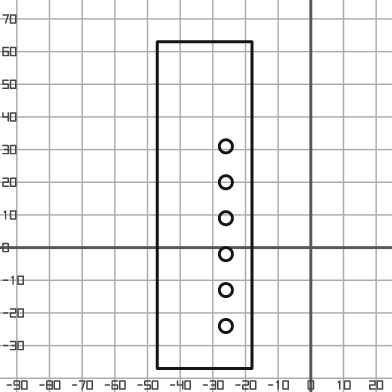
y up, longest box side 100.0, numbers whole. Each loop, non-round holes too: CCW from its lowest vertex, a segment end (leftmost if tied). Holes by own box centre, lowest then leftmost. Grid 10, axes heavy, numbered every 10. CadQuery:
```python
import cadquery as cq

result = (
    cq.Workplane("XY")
    .moveTo(-47.0, -37.0)
    .lineTo(-18.0, -37.0)
    .lineTo(-18.0, 63.0)
    .lineTo(-47.0, 63.0)
    .close()
    .moveTo(-26.0, -24.0)
    .circle(2.0)
    .moveTo(-26.0, -13.0)
    .circle(2.0)
    .moveTo(-26.0, -2.0)
    .circle(2.0)
    .moveTo(-26.0, 9.0)
    .circle(2.0)
    .moveTo(-26.0, 20.0)
    .circle(2.0)
    .moveTo(-26.0, 31.0)
    .circle(2.0)
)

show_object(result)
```